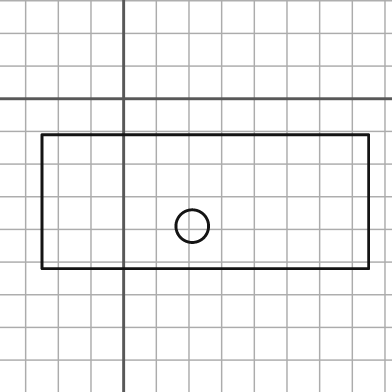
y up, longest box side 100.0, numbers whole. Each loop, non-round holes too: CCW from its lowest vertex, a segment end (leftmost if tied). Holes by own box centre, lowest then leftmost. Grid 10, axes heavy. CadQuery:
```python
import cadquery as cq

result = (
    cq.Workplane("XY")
    .moveTo(-25.0, -52.0)
    .lineTo(75.0, -52.0)
    .lineTo(75.0, -11.0)
    .lineTo(-25.0, -11.0)
    .close()
    .moveTo(21.0, -39.0)
    .circle(5.0)
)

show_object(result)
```